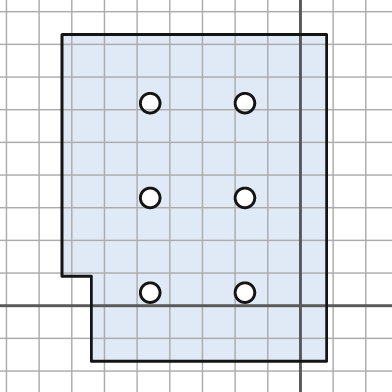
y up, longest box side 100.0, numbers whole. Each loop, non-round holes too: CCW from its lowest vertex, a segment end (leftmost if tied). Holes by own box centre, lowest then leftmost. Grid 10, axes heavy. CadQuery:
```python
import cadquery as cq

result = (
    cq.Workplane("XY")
    .moveTo(-64.0, -17.0)
    .lineTo(8.0, -17.0)
    .lineTo(8.0, 83.0)
    .lineTo(-73.0, 83.0)
    .lineTo(-73.0, 9.0)
    .lineTo(-64.0, 9.0)
    .close()
    .moveTo(-46.0, 4.0)
    .circle(3.0)
    .moveTo(-17.0, 4.0)
    .circle(3.0)
    .moveTo(-46.0, 33.0)
    .circle(3.0)
    .moveTo(-17.0, 33.0)
    .circle(3.0)
    .moveTo(-46.0, 62.0)
    .circle(3.0)
    .moveTo(-17.0, 62.0)
    .circle(3.0)
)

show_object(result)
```